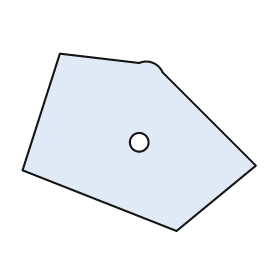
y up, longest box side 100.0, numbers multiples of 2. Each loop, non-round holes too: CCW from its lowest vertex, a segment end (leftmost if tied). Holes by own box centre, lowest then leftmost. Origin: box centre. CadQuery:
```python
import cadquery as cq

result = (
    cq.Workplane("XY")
    .moveTo(16.0, -38.0)
    .lineTo(50.0, -10.0)
    .lineTo(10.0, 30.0)
    .threePointArc((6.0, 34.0), (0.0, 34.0))
    .lineTo(-34.0, 38.0)
    .lineTo(-50.0, -12.0)
    .close()
    .moveTo(0.0, 0.0)
    .circle(4.0)
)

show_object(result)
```